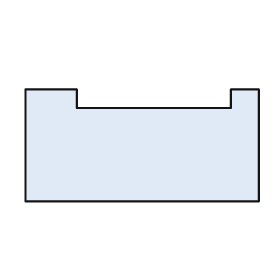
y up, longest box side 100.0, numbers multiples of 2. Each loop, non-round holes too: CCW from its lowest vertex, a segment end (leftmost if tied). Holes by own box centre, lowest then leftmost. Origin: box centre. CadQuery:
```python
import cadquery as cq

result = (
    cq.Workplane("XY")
    .moveTo(-50.0, -24.0)
    .lineTo(50.0, -24.0)
    .lineTo(50.0, 24.0)
    .lineTo(38.0, 24.0)
    .lineTo(38.0, 16.0)
    .lineTo(-28.0, 16.0)
    .lineTo(-28.0, 24.0)
    .lineTo(-50.0, 24.0)
    .close()
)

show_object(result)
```